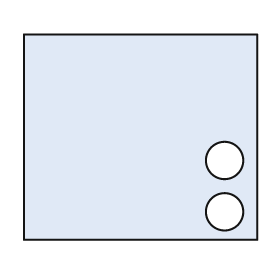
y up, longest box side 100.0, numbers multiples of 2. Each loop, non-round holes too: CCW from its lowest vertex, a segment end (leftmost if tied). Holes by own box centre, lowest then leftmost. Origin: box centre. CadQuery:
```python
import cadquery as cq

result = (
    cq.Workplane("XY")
    .moveTo(-50.0, -44.0)
    .lineTo(50.0, -44.0)
    .lineTo(50.0, 44.0)
    .lineTo(-50.0, 44.0)
    .close()
    .moveTo(36.0, -32.0)
    .circle(8.0)
    .moveTo(36.0, -10.0)
    .circle(8.0)
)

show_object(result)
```